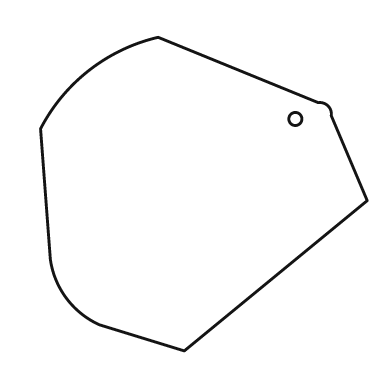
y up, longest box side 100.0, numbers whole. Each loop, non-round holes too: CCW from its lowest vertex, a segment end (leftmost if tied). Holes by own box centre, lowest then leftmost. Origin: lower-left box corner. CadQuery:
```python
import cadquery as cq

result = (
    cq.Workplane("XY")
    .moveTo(44.0, 0.0)
    .lineTo(100.0, 46.0)
    .lineTo(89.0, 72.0)
    .threePointArc((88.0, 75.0), (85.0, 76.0))
    .lineTo(36.0, 96.0)
    .threePointArc((15.0, 86.0), (0.0, 68.0))
    .lineTo(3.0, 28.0)
    .threePointArc((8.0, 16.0), (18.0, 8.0))
    .close()
    .moveTo(78.0, 71.0)
    .circle(2.0)
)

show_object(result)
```